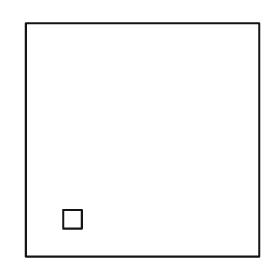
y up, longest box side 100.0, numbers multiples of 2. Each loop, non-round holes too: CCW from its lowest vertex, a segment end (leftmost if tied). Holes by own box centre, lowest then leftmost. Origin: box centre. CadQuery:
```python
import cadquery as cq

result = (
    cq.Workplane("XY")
    .moveTo(-50.0, -50.0)
    .lineTo(50.0, -50.0)
    .lineTo(50.0, 50.0)
    .lineTo(-50.0, 50.0)
    .close()
    .moveTo(-34.0, -38.0)
    .lineTo(-26.0, -38.0)
    .lineTo(-26.0, -30.0)
    .lineTo(-34.0, -30.0)
    .close()
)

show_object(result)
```